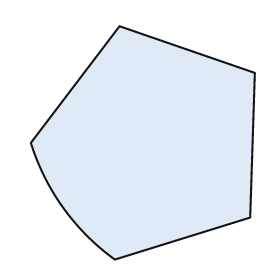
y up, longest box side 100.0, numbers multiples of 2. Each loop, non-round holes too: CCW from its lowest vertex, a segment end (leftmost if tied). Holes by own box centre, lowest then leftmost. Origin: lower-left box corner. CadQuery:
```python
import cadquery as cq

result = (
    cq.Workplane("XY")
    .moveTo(36.0, 0.0)
    .lineTo(94.0, 18.0)
    .lineTo(96.0, 80.0)
    .lineTo(38.0, 100.0)
    .lineTo(0.0, 50.0)
    .threePointArc((14.0, 22.0), (36.0, 0.0))
    .close()
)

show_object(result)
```